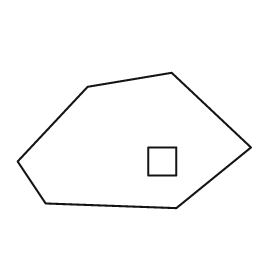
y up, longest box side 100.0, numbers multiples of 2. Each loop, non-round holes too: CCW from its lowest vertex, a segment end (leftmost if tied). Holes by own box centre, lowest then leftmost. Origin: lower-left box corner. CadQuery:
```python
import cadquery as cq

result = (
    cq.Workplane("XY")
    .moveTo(68.0, 0.0)
    .lineTo(100.0, 26.0)
    .lineTo(66.0, 58.0)
    .lineTo(30.0, 52.0)
    .lineTo(0.0, 20.0)
    .lineTo(12.0, 2.0)
    .close()
    .moveTo(56.0, 14.0)
    .lineTo(68.0, 14.0)
    .lineTo(68.0, 26.0)
    .lineTo(56.0, 26.0)
    .close()
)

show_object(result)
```